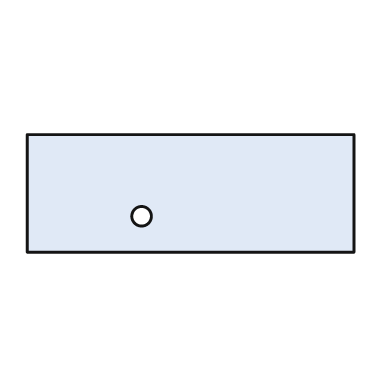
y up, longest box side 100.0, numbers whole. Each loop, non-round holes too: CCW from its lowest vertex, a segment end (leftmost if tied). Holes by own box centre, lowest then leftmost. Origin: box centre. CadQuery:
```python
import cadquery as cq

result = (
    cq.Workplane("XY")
    .moveTo(-50.0, -18.0)
    .lineTo(50.0, -18.0)
    .lineTo(50.0, 18.0)
    .lineTo(-50.0, 18.0)
    .close()
    .moveTo(-15.0, -7.0)
    .circle(3.0)
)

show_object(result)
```